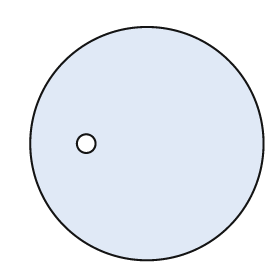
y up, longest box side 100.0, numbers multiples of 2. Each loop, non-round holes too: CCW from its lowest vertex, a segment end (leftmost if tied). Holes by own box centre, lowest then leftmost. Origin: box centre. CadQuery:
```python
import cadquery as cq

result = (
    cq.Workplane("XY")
    .moveTo(0.0, 0.0)
    .circle(50.0)
    .moveTo(-26.0, 0.0)
    .circle(4.0)
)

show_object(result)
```